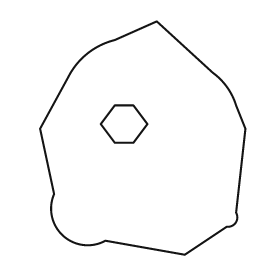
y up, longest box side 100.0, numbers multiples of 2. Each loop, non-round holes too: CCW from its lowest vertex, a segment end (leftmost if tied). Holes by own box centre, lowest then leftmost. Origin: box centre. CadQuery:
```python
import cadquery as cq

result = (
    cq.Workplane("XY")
    .moveTo(18.0, -50.0)
    .lineTo(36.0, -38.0)
    .threePointArc((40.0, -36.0), (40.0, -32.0))
    .lineTo(44.0, 4.0)
    .lineTo(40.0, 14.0)
    .threePointArc((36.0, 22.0), (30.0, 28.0))
    .lineTo(6.0, 50.0)
    .lineTo(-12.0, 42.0)
    .threePointArc((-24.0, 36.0), (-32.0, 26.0))
    .lineTo(-44.0, 4.0)
    .lineTo(-38.0, -24.0)
    .threePointArc((-34.0, -42.0), (-16.0, -44.0))
    .close()
    .moveTo(-12.0, -2.0)
    .lineTo(-4.0, -2.0)
    .lineTo(2.0, 6.0)
    .lineTo(-4.0, 14.0)
    .lineTo(-12.0, 14.0)
    .lineTo(-18.0, 6.0)
    .close()
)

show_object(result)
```